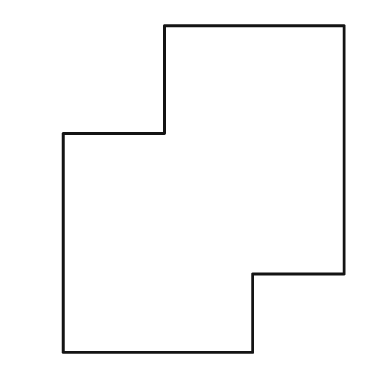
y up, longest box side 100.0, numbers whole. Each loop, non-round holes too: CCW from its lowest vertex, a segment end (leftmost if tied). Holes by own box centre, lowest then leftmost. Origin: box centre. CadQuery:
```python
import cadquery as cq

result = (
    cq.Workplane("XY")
    .moveTo(-43.0, -50.0)
    .lineTo(15.0, -50.0)
    .lineTo(15.0, -26.0)
    .lineTo(43.0, -26.0)
    .lineTo(43.0, 50.0)
    .lineTo(-12.0, 50.0)
    .lineTo(-12.0, 17.0)
    .lineTo(-43.0, 17.0)
    .close()
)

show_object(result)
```